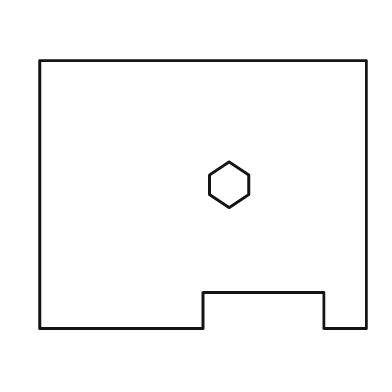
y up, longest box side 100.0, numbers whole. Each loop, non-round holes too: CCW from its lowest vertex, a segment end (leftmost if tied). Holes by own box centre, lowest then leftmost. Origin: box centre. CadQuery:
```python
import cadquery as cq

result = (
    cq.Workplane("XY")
    .moveTo(-50.0, -41.0)
    .lineTo(0.0, -41.0)
    .lineTo(0.0, -30.0)
    .lineTo(37.0, -30.0)
    .lineTo(37.0, -41.0)
    .lineTo(50.0, -41.0)
    .lineTo(50.0, 41.0)
    .lineTo(-50.0, 41.0)
    .close()
    .moveTo(8.0, -4.0)
    .lineTo(14.0, 0.0)
    .lineTo(14.0, 6.0)
    .lineTo(8.0, 10.0)
    .lineTo(2.0, 6.0)
    .lineTo(2.0, 0.0)
    .close()
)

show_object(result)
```